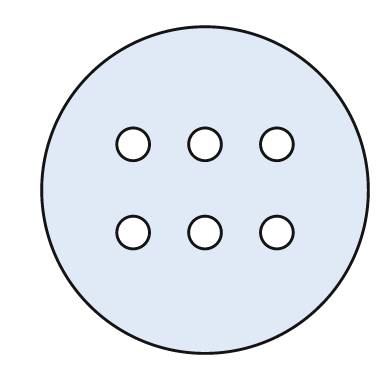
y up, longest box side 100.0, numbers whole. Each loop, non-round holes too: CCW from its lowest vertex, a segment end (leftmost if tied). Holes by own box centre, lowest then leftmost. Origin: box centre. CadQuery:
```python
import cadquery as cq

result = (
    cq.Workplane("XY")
    .moveTo(0.0, 0.0)
    .circle(50.0)
    .moveTo(-22.0, -13.0)
    .circle(5.0)
    .moveTo(0.0, -13.0)
    .circle(5.0)
    .moveTo(22.0, -13.0)
    .circle(5.0)
    .moveTo(-22.0, 14.0)
    .circle(5.0)
    .moveTo(0.0, 14.0)
    .circle(5.0)
    .moveTo(22.0, 14.0)
    .circle(5.0)
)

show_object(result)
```